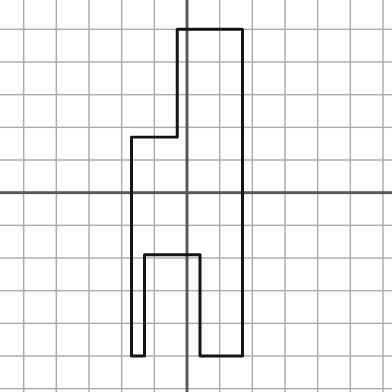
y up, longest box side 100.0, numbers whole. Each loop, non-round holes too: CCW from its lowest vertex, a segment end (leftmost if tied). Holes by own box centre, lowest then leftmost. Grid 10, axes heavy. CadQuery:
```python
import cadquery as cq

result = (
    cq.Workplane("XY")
    .moveTo(-17.0, -50.0)
    .lineTo(-13.0, -50.0)
    .lineTo(-13.0, -19.0)
    .lineTo(4.0, -19.0)
    .lineTo(4.0, -50.0)
    .lineTo(17.0, -50.0)
    .lineTo(17.0, 50.0)
    .lineTo(-3.0, 50.0)
    .lineTo(-3.0, 17.0)
    .lineTo(-17.0, 17.0)
    .close()
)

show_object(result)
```